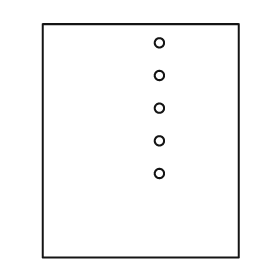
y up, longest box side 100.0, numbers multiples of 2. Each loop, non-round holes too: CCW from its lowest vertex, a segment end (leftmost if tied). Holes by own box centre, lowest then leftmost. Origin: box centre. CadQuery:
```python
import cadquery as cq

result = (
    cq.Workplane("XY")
    .moveTo(-42.0, -50.0)
    .lineTo(42.0, -50.0)
    .lineTo(42.0, 50.0)
    .lineTo(-42.0, 50.0)
    .close()
    .moveTo(8.0, -14.0)
    .circle(2.0)
    .moveTo(8.0, 0.0)
    .circle(2.0)
    .moveTo(8.0, 14.0)
    .circle(2.0)
    .moveTo(8.0, 28.0)
    .circle(2.0)
    .moveTo(8.0, 42.0)
    .circle(2.0)
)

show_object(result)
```